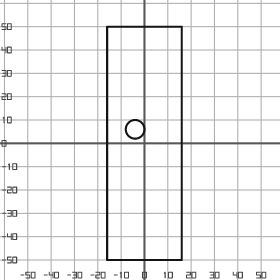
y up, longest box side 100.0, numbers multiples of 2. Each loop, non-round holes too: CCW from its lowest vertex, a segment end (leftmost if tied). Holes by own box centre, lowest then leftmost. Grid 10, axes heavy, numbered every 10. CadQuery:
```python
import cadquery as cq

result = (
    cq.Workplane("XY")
    .moveTo(-16.0, -50.0)
    .lineTo(16.0, -50.0)
    .lineTo(16.0, 50.0)
    .lineTo(-16.0, 50.0)
    .close()
    .moveTo(-4.0, 6.0)
    .circle(4.0)
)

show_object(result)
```